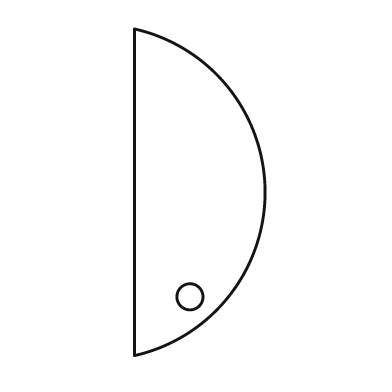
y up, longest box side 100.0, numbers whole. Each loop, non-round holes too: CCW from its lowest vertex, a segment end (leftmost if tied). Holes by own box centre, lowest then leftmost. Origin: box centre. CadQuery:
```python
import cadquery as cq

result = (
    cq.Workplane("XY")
    .moveTo(-20.0, -50.0)
    .threePointArc((20.0, 0.0), (-20.0, 50.0))
    .close()
    .moveTo(-3.0, -32.0)
    .circle(4.0)
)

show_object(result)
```